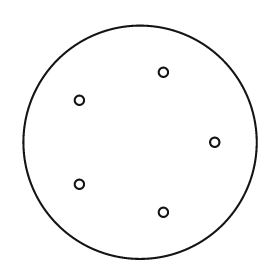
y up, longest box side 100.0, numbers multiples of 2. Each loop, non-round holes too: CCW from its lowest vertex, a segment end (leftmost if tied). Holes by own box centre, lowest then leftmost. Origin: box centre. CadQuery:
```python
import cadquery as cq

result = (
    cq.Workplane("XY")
    .moveTo(0.0, 0.0)
    .circle(50.0)
    .moveTo(10.0, -30.0)
    .circle(2.0)
    .moveTo(-26.0, -18.0)
    .circle(2.0)
    .moveTo(32.0, 0.0)
    .circle(2.0)
    .moveTo(-26.0, 18.0)
    .circle(2.0)
    .moveTo(10.0, 30.0)
    .circle(2.0)
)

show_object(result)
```